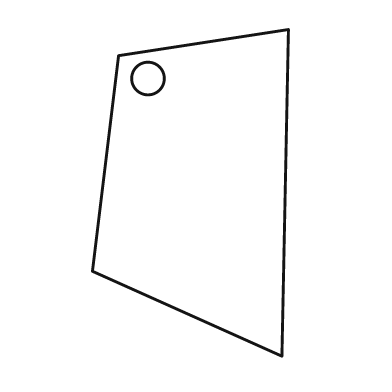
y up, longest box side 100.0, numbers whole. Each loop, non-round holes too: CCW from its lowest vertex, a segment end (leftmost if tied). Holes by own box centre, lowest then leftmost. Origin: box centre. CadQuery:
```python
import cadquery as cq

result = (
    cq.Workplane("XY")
    .moveTo(28.0, -50.0)
    .lineTo(30.0, 50.0)
    .lineTo(-22.0, 42.0)
    .lineTo(-30.0, -24.0)
    .close()
    .moveTo(-13.0, 35.0)
    .circle(5.0)
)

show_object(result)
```